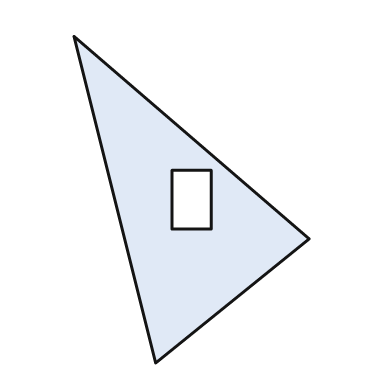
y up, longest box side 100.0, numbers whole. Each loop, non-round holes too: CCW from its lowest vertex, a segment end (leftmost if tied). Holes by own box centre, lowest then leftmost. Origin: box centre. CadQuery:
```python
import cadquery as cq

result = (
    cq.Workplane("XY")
    .moveTo(-11.0, -50.0)
    .lineTo(36.0, -12.0)
    .lineTo(-36.0, 50.0)
    .close()
    .moveTo(-6.0, -9.0)
    .lineTo(6.0, -9.0)
    .lineTo(6.0, 9.0)
    .lineTo(-6.0, 9.0)
    .close()
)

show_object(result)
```